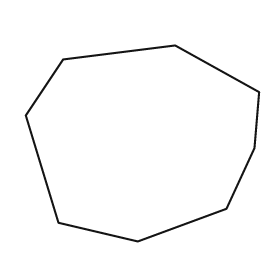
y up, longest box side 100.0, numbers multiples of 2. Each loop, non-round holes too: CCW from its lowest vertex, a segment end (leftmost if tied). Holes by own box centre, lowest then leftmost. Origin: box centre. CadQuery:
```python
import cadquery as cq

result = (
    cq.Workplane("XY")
    .moveTo(-2.0, -42.0)
    .lineTo(36.0, -28.0)
    .lineTo(48.0, -2.0)
    .lineTo(50.0, 22.0)
    .lineTo(14.0, 42.0)
    .lineTo(-34.0, 36.0)
    .lineTo(-50.0, 12.0)
    .lineTo(-36.0, -34.0)
    .close()
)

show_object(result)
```